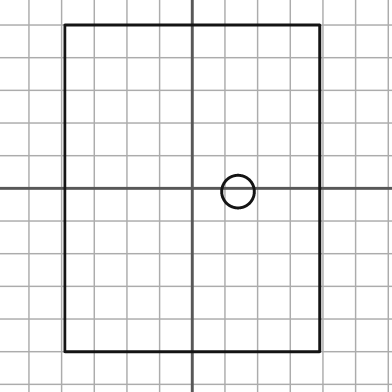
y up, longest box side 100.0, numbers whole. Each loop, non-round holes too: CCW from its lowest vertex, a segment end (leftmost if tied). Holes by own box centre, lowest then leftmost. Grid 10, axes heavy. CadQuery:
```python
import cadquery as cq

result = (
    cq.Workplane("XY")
    .moveTo(-39.0, -50.0)
    .lineTo(39.0, -50.0)
    .lineTo(39.0, 50.0)
    .lineTo(-39.0, 50.0)
    .close()
    .moveTo(14.0, -1.0)
    .circle(5.0)
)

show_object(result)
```